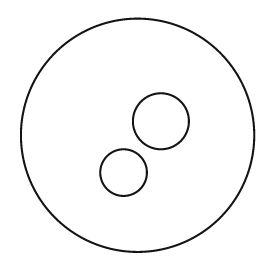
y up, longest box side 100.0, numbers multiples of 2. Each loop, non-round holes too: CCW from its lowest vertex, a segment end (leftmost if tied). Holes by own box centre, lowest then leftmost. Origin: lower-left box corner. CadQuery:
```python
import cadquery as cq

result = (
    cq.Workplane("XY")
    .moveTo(50.0, 50.0)
    .circle(50.0)
    .moveTo(44.0, 34.0)
    .circle(10.0)
    .moveTo(60.0, 56.0)
    .circle(12.0)
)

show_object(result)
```